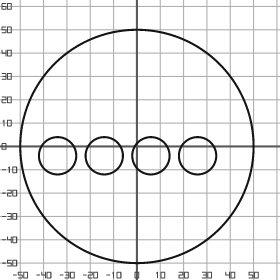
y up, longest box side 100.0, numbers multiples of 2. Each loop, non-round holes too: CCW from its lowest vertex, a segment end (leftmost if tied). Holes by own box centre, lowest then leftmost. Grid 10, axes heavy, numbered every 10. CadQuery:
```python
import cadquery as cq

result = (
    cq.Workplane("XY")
    .moveTo(0.0, 0.0)
    .circle(50.0)
    .moveTo(-34.0, -4.0)
    .circle(8.0)
    .moveTo(-14.0, -4.0)
    .circle(8.0)
    .moveTo(6.0, -4.0)
    .circle(8.0)
    .moveTo(26.0, -4.0)
    .circle(8.0)
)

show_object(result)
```